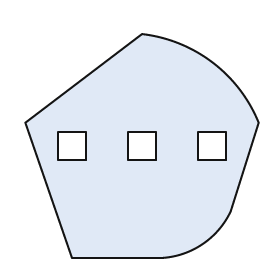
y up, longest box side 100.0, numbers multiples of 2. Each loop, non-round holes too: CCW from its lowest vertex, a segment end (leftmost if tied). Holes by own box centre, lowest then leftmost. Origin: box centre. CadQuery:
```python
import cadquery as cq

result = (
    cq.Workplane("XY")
    .moveTo(-30.0, -48.0)
    .lineTo(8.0, -48.0)
    .threePointArc((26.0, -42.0), (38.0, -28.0))
    .lineTo(50.0, 10.0)
    .threePointArc((30.0, 36.0), (0.0, 48.0))
    .lineTo(-50.0, 10.0)
    .close()
    .moveTo(-36.0, -6.0)
    .lineTo(-24.0, -6.0)
    .lineTo(-24.0, 6.0)
    .lineTo(-36.0, 6.0)
    .close()
    .moveTo(-6.0, -6.0)
    .lineTo(6.0, -6.0)
    .lineTo(6.0, 6.0)
    .lineTo(-6.0, 6.0)
    .close()
    .moveTo(24.0, -6.0)
    .lineTo(36.0, -6.0)
    .lineTo(36.0, 6.0)
    .lineTo(24.0, 6.0)
    .close()
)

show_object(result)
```